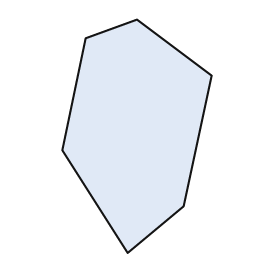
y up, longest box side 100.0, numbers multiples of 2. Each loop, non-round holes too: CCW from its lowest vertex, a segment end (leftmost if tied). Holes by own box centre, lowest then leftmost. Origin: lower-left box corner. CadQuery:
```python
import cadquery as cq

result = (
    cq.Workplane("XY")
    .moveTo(28.0, 0.0)
    .lineTo(52.0, 20.0)
    .lineTo(64.0, 76.0)
    .lineTo(32.0, 100.0)
    .lineTo(10.0, 92.0)
    .lineTo(0.0, 44.0)
    .close()
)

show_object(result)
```